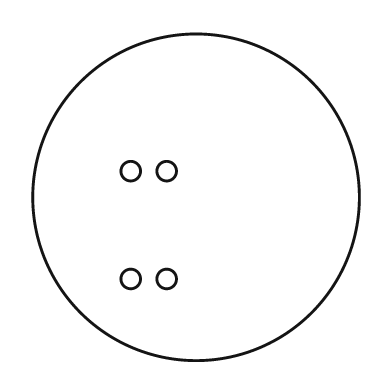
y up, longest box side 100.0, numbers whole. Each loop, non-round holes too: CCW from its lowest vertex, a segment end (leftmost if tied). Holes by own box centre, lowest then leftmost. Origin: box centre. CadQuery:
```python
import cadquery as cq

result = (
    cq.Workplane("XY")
    .moveTo(0.0, 0.0)
    .circle(50.0)
    .moveTo(-20.0, -25.0)
    .circle(3.0)
    .moveTo(-9.0, -25.0)
    .circle(3.0)
    .moveTo(-20.0, 8.0)
    .circle(3.0)
    .moveTo(-9.0, 8.0)
    .circle(3.0)
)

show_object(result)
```